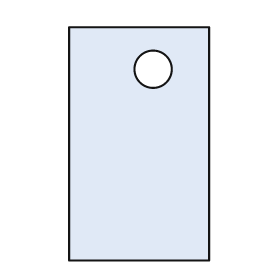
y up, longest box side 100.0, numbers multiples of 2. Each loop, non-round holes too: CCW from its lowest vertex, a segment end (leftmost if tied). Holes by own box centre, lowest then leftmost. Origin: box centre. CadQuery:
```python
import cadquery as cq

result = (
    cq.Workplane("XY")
    .moveTo(-30.0, -50.0)
    .lineTo(30.0, -50.0)
    .lineTo(30.0, 50.0)
    .lineTo(-30.0, 50.0)
    .close()
    .moveTo(6.0, 32.0)
    .circle(8.0)
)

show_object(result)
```